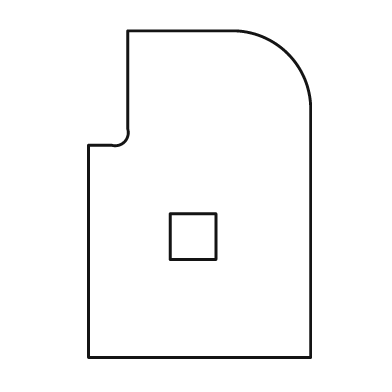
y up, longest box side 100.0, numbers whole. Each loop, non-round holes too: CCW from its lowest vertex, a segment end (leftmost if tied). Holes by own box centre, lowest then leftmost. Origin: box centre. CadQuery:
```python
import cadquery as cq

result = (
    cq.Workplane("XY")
    .moveTo(-34.0, -50.0)
    .lineTo(34.0, -50.0)
    .lineTo(34.0, 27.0)
    .threePointArc((27.0, 43.0), (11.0, 50.0))
    .lineTo(-22.0, 50.0)
    .lineTo(-22.0, 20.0)
    .threePointArc((-23.0, 16.0), (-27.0, 15.0))
    .lineTo(-34.0, 15.0)
    .close()
    .moveTo(-9.0, -20.0)
    .lineTo(5.0, -20.0)
    .lineTo(5.0, -6.0)
    .lineTo(-9.0, -6.0)
    .close()
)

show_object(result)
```